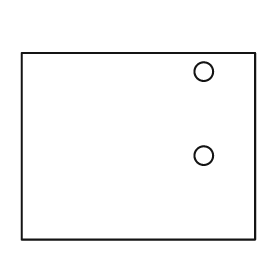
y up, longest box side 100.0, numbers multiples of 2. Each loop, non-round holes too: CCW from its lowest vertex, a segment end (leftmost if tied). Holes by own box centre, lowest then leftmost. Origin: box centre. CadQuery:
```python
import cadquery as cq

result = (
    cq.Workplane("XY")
    .moveTo(-50.0, -40.0)
    .lineTo(50.0, -40.0)
    .lineTo(50.0, 40.0)
    .lineTo(-50.0, 40.0)
    .close()
    .moveTo(28.0, -4.0)
    .circle(4.0)
    .moveTo(28.0, 32.0)
    .circle(4.0)
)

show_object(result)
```